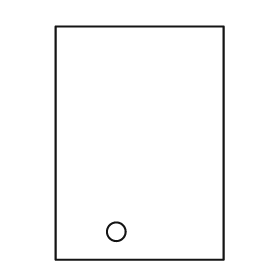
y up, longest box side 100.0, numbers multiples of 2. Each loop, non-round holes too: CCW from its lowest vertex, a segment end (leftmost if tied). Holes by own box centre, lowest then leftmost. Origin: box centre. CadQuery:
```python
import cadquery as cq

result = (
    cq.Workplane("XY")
    .moveTo(-36.0, -50.0)
    .lineTo(36.0, -50.0)
    .lineTo(36.0, 50.0)
    .lineTo(-36.0, 50.0)
    .close()
    .moveTo(-10.0, -38.0)
    .circle(4.0)
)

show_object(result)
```